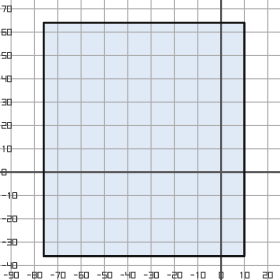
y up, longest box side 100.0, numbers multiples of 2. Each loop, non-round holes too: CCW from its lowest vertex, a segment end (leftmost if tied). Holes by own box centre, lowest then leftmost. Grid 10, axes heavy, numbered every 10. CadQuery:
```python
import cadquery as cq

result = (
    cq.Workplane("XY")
    .moveTo(-76.0, -36.0)
    .lineTo(10.0, -36.0)
    .lineTo(10.0, 64.0)
    .lineTo(-76.0, 64.0)
    .close()
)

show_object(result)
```